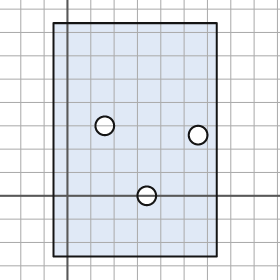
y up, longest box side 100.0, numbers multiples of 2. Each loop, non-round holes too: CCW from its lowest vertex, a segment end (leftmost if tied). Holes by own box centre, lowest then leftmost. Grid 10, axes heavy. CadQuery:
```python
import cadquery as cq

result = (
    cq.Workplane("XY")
    .moveTo(-6.0, -26.0)
    .lineTo(64.0, -26.0)
    .lineTo(64.0, 74.0)
    .lineTo(-6.0, 74.0)
    .close()
    .moveTo(34.0, 0.0)
    .circle(4.0)
    .moveTo(56.0, 26.0)
    .circle(4.0)
    .moveTo(16.0, 30.0)
    .circle(4.0)
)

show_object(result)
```